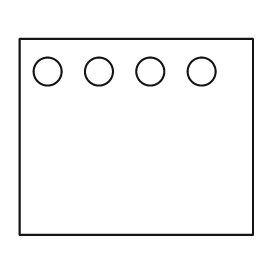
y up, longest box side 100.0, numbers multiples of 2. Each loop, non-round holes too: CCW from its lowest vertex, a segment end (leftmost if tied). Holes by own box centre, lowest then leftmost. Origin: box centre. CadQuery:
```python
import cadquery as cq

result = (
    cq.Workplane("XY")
    .moveTo(-50.0, -42.0)
    .lineTo(50.0, -42.0)
    .lineTo(50.0, 42.0)
    .lineTo(-50.0, 42.0)
    .close()
    .moveTo(-38.0, 28.0)
    .circle(6.0)
    .moveTo(-16.0, 28.0)
    .circle(6.0)
    .moveTo(6.0, 28.0)
    .circle(6.0)
    .moveTo(28.0, 28.0)
    .circle(6.0)
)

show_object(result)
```